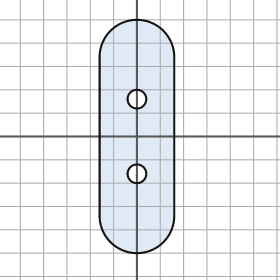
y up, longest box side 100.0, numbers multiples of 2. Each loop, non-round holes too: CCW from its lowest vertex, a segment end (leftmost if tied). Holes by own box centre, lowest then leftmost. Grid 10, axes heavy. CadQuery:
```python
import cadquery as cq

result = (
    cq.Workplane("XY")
    .moveTo(-16.0, -34.0)
    .threePointArc((0.0, -50.0), (16.0, -34.0))
    .lineTo(16.0, 34.0)
    .threePointArc((0.0, 50.0), (-16.0, 34.0))
    .close()
    .moveTo(0.0, -16.0)
    .circle(4.0)
    .moveTo(0.0, 16.0)
    .circle(4.0)
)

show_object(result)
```